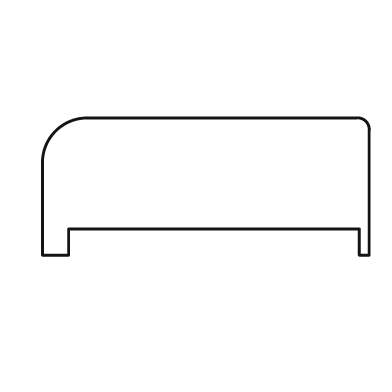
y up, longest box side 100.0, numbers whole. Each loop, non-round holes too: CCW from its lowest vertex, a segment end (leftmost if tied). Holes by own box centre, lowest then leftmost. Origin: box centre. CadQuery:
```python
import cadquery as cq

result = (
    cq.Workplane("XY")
    .moveTo(-50.0, -21.0)
    .lineTo(-42.0, -21.0)
    .lineTo(-42.0, -13.0)
    .lineTo(47.0, -13.0)
    .lineTo(47.0, -21.0)
    .lineTo(50.0, -21.0)
    .lineTo(50.0, 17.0)
    .threePointArc((49.0, 20.0), (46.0, 21.0))
    .lineTo(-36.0, 21.0)
    .threePointArc((-46.0, 17.0), (-50.0, 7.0))
    .close()
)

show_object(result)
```